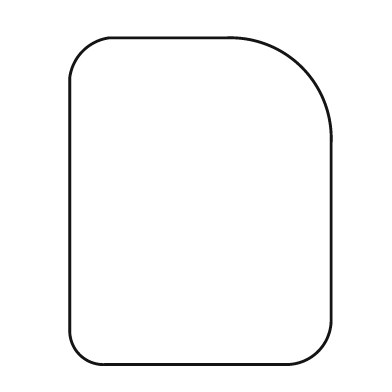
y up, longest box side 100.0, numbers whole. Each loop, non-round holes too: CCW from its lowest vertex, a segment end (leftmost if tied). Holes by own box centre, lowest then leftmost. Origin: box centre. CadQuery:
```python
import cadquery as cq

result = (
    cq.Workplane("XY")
    .moveTo(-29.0, -50.0)
    .lineTo(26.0, -50.0)
    .threePointArc((36.0, -46.0), (40.0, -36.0))
    .lineTo(40.0, 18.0)
    .threePointArc((31.0, 41.0), (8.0, 50.0))
    .lineTo(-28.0, 50.0)
    .threePointArc((-36.0, 46.0), (-40.0, 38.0))
    .lineTo(-40.0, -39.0)
    .threePointArc((-37.0, -47.0), (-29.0, -50.0))
    .close()
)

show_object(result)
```